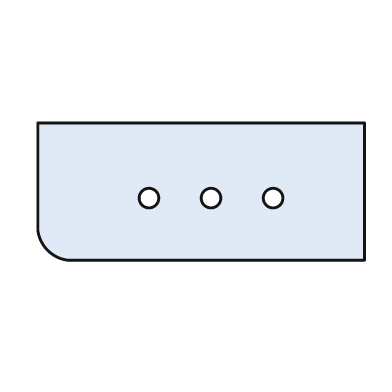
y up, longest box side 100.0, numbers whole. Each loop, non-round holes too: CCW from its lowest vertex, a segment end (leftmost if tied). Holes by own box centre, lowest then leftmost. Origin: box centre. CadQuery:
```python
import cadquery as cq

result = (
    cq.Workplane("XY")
    .moveTo(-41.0, -21.0)
    .lineTo(50.0, -21.0)
    .lineTo(50.0, 21.0)
    .lineTo(-50.0, 21.0)
    .lineTo(-50.0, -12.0)
    .threePointArc((-47.0, -18.0), (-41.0, -21.0))
    .close()
    .moveTo(-16.0, -2.0)
    .circle(3.0)
    .moveTo(3.0, -2.0)
    .circle(3.0)
    .moveTo(22.0, -2.0)
    .circle(3.0)
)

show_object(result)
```